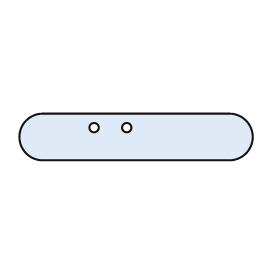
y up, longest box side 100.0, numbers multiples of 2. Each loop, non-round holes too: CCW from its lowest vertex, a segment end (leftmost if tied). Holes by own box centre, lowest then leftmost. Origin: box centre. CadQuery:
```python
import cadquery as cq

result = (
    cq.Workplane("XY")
    .moveTo(-40.0, -10.0)
    .lineTo(40.0, -10.0)
    .threePointArc((50.0, 0.0), (40.0, 10.0))
    .lineTo(-40.0, 10.0)
    .threePointArc((-50.0, 0.0), (-40.0, -10.0))
    .close()
    .moveTo(-18.0, 4.0)
    .circle(2.0)
    .moveTo(-4.0, 4.0)
    .circle(2.0)
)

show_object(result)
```